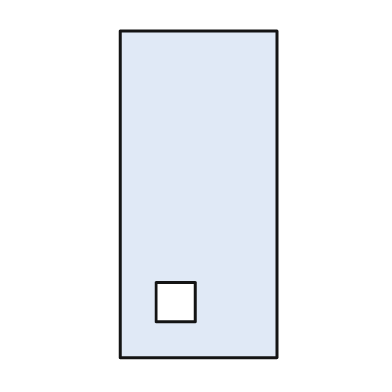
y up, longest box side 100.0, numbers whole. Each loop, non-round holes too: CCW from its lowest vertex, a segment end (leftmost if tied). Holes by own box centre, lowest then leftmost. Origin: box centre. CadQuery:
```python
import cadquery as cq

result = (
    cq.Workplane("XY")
    .moveTo(-24.0, -50.0)
    .lineTo(24.0, -50.0)
    .lineTo(24.0, 50.0)
    .lineTo(-24.0, 50.0)
    .close()
    .moveTo(-13.0, -39.0)
    .lineTo(-1.0, -39.0)
    .lineTo(-1.0, -27.0)
    .lineTo(-13.0, -27.0)
    .close()
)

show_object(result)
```